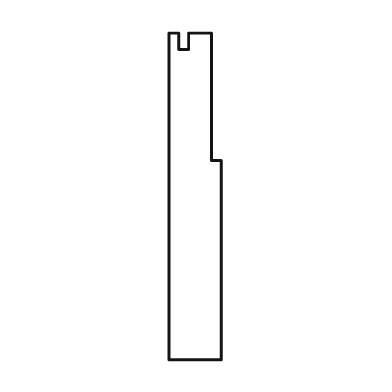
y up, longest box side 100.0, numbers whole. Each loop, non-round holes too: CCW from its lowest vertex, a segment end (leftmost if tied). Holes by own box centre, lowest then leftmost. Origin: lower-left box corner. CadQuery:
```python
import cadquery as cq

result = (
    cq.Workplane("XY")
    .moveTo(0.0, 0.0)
    .lineTo(16.0, 0.0)
    .lineTo(16.0, 61.0)
    .lineTo(13.0, 61.0)
    .lineTo(13.0, 100.0)
    .lineTo(6.0, 100.0)
    .lineTo(6.0, 95.0)
    .lineTo(3.0, 95.0)
    .lineTo(3.0, 100.0)
    .lineTo(0.0, 100.0)
    .close()
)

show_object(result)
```